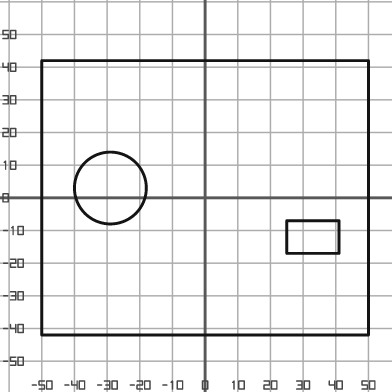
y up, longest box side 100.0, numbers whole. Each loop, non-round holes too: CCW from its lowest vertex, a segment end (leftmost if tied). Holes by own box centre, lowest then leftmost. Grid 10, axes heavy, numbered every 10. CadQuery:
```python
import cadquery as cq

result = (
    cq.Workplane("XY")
    .moveTo(-50.0, -42.0)
    .lineTo(50.0, -42.0)
    .lineTo(50.0, 42.0)
    .lineTo(-50.0, 42.0)
    .close()
    .moveTo(25.0, -17.0)
    .lineTo(41.0, -17.0)
    .lineTo(41.0, -7.0)
    .lineTo(25.0, -7.0)
    .close()
    .moveTo(-29.0, 3.0)
    .circle(11.0)
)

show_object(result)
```